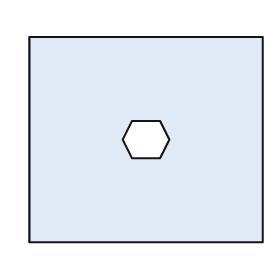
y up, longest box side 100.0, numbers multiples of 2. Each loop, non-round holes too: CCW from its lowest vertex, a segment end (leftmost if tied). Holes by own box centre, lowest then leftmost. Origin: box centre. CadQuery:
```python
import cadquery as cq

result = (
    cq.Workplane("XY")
    .moveTo(-50.0, -44.0)
    .lineTo(50.0, -44.0)
    .lineTo(50.0, 44.0)
    .lineTo(-50.0, 44.0)
    .close()
    .moveTo(-6.0, -8.0)
    .lineTo(6.0, -8.0)
    .lineTo(10.0, 0.0)
    .lineTo(6.0, 8.0)
    .lineTo(-6.0, 8.0)
    .lineTo(-10.0, 0.0)
    .close()
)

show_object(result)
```